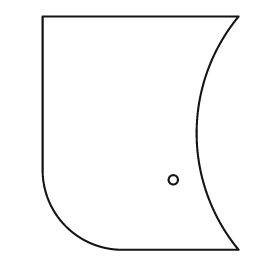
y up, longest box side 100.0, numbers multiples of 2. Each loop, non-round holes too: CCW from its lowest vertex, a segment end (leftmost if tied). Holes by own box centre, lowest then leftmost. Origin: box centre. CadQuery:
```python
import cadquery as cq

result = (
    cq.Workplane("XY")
    .moveTo(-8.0, -50.0)
    .lineTo(42.0, -50.0)
    .threePointArc((24.0, 0.0), (42.0, 50.0))
    .lineTo(-42.0, 50.0)
    .lineTo(-42.0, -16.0)
    .threePointArc((-32.0, -40.0), (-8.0, -50.0))
    .close()
    .moveTo(14.0, -20.0)
    .circle(2.0)
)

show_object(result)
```